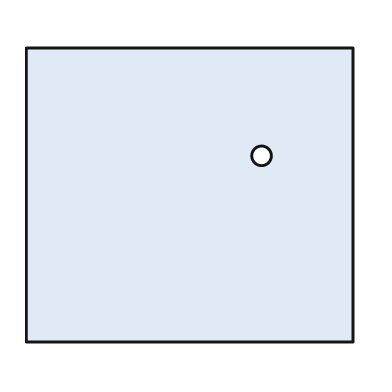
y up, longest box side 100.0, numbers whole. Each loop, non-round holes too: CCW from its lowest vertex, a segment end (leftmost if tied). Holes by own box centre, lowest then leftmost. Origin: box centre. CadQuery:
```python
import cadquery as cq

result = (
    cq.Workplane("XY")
    .moveTo(-50.0, -45.0)
    .lineTo(50.0, -45.0)
    .lineTo(50.0, 45.0)
    .lineTo(-50.0, 45.0)
    .close()
    .moveTo(22.0, 12.0)
    .circle(3.0)
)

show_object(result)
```